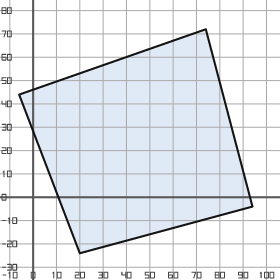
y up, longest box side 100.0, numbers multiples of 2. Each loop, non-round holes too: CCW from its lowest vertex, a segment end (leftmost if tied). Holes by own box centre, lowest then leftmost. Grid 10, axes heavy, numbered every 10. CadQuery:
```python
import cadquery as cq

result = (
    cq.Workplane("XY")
    .moveTo(20.0, -24.0)
    .lineTo(94.0, -4.0)
    .lineTo(74.0, 72.0)
    .lineTo(-6.0, 44.0)
    .close()
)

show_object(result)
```